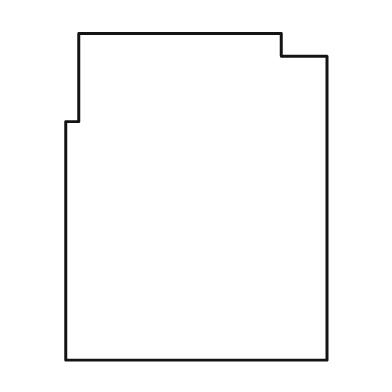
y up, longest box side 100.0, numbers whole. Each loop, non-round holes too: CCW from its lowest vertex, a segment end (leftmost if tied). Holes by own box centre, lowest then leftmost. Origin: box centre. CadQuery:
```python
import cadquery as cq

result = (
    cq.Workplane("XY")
    .moveTo(-40.0, -50.0)
    .lineTo(40.0, -50.0)
    .lineTo(40.0, 43.0)
    .lineTo(26.0, 43.0)
    .lineTo(26.0, 50.0)
    .lineTo(-36.0, 50.0)
    .lineTo(-36.0, 23.0)
    .lineTo(-40.0, 23.0)
    .close()
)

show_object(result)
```